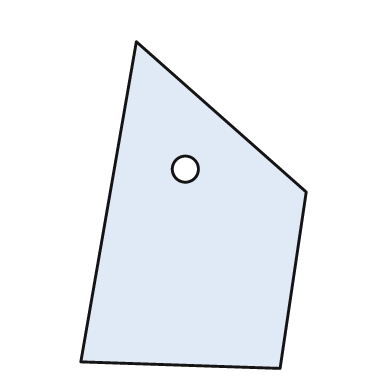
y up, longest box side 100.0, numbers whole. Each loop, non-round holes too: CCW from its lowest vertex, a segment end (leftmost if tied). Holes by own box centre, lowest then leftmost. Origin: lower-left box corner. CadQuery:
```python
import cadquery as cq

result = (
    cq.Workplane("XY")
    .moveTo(61.0, 0.0)
    .lineTo(69.0, 54.0)
    .lineTo(17.0, 100.0)
    .lineTo(0.0, 2.0)
    .close()
    .moveTo(32.0, 61.0)
    .circle(4.0)
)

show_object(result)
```